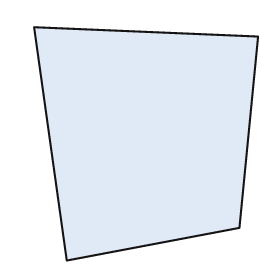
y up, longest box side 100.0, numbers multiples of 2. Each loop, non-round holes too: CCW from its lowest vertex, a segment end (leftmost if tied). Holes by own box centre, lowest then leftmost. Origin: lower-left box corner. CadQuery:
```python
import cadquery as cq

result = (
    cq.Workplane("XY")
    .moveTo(14.0, 0.0)
    .lineTo(88.0, 14.0)
    .lineTo(96.0, 96.0)
    .lineTo(0.0, 100.0)
    .close()
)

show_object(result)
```